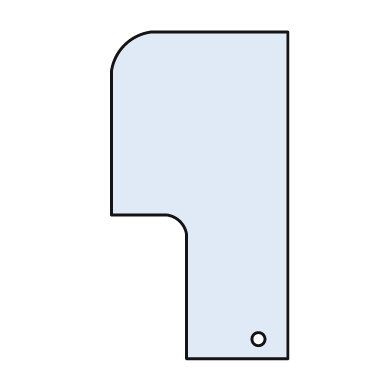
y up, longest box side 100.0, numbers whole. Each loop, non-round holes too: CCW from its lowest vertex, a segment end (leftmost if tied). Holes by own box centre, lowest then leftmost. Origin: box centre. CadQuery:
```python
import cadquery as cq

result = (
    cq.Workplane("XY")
    .moveTo(-4.0, -50.0)
    .lineTo(27.0, -50.0)
    .lineTo(27.0, 50.0)
    .lineTo(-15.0, 50.0)
    .threePointArc((-23.0, 46.0), (-27.0, 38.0))
    .lineTo(-27.0, -6.0)
    .lineTo(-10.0, -6.0)
    .threePointArc((-6.0, -8.0), (-4.0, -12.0))
    .close()
    .moveTo(18.0, -44.0)
    .circle(2.0)
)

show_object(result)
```